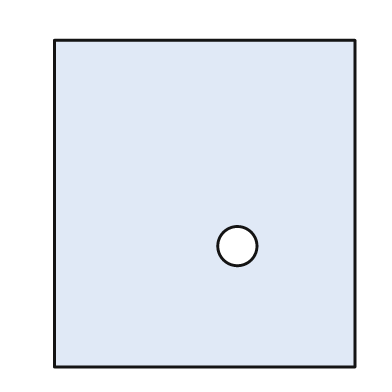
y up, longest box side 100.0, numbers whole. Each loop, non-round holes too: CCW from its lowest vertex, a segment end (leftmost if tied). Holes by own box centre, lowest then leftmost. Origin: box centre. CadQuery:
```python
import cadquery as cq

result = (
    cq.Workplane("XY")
    .moveTo(-46.0, -50.0)
    .lineTo(46.0, -50.0)
    .lineTo(46.0, 50.0)
    .lineTo(-46.0, 50.0)
    .close()
    .moveTo(10.0, -13.0)
    .circle(6.0)
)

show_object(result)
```